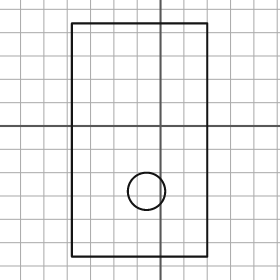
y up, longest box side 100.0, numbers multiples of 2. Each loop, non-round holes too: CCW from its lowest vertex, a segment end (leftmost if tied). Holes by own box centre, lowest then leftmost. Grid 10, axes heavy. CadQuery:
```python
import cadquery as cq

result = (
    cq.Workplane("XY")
    .moveTo(-38.0, -56.0)
    .lineTo(20.0, -56.0)
    .lineTo(20.0, 44.0)
    .lineTo(-38.0, 44.0)
    .close()
    .moveTo(-6.0, -28.0)
    .circle(8.0)
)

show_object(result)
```